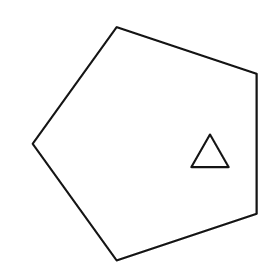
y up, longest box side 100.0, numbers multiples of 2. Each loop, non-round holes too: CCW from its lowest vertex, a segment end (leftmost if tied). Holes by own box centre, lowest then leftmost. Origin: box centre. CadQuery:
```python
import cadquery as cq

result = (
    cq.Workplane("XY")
    .moveTo(-12.0, -50.0)
    .lineTo(48.0, -30.0)
    .lineTo(48.0, 30.0)
    .lineTo(-12.0, 50.0)
    .lineTo(-48.0, 0.0)
    .close()
    .moveTo(20.0, -10.0)
    .lineTo(36.0, -10.0)
    .lineTo(28.0, 4.0)
    .close()
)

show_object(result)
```